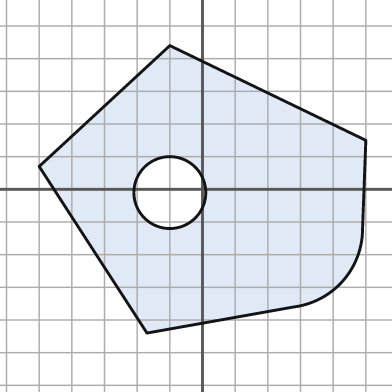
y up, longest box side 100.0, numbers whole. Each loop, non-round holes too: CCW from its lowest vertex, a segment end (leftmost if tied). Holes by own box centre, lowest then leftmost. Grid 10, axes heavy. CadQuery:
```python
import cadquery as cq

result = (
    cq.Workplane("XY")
    .moveTo(-17.0, -44.0)
    .lineTo(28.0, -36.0)
    .threePointArc((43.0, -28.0), (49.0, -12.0))
    .lineTo(50.0, 15.0)
    .lineTo(-10.0, 44.0)
    .lineTo(-50.0, 7.0)
    .close()
    .moveTo(-10.0, -1.0)
    .circle(11.0)
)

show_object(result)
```